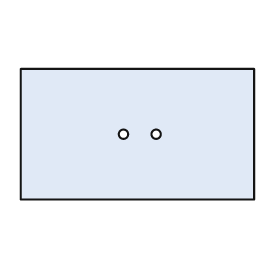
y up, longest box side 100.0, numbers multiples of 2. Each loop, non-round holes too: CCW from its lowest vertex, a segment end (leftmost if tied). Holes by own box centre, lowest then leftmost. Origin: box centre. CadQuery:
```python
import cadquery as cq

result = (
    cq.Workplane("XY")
    .moveTo(-50.0, -28.0)
    .lineTo(50.0, -28.0)
    .lineTo(50.0, 28.0)
    .lineTo(-50.0, 28.0)
    .close()
    .moveTo(-6.0, 0.0)
    .circle(2.0)
    .moveTo(8.0, 0.0)
    .circle(2.0)
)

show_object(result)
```